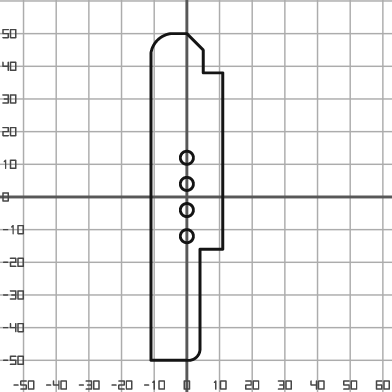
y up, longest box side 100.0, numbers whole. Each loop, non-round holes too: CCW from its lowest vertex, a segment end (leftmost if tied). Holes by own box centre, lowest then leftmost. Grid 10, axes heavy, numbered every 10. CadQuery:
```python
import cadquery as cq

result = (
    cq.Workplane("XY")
    .moveTo(-11.0, -50.0)
    .lineTo(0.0, -50.0)
    .threePointArc((3.0, -49.0), (4.0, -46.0))
    .lineTo(4.0, -16.0)
    .lineTo(11.0, -16.0)
    .lineTo(11.0, 38.0)
    .lineTo(5.0, 38.0)
    .lineTo(5.0, 45.0)
    .lineTo(0.0, 50.0)
    .lineTo(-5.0, 50.0)
    .threePointArc((-9.0, 48.0), (-11.0, 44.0))
    .close()
    .moveTo(0.0, -12.0)
    .circle(2.0)
    .moveTo(0.0, -4.0)
    .circle(2.0)
    .moveTo(0.0, 4.0)
    .circle(2.0)
    .moveTo(0.0, 12.0)
    .circle(2.0)
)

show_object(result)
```